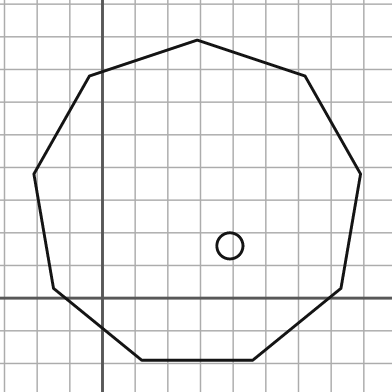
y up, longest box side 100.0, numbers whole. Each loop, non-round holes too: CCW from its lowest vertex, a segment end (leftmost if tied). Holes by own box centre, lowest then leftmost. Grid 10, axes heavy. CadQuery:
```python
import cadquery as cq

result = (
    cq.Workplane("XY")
    .moveTo(12.0, -19.0)
    .lineTo(46.0, -19.0)
    .lineTo(73.0, 3.0)
    .lineTo(79.0, 38.0)
    .lineTo(62.0, 68.0)
    .lineTo(29.0, 79.0)
    .lineTo(-4.0, 68.0)
    .lineTo(-21.0, 38.0)
    .lineTo(-15.0, 3.0)
    .close()
    .moveTo(39.0, 16.0)
    .circle(4.0)
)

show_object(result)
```